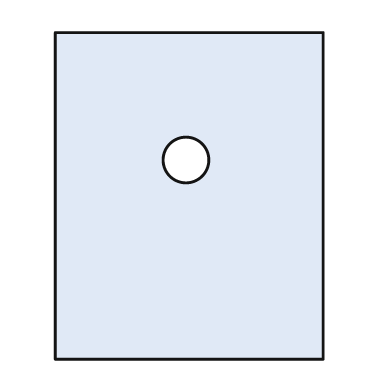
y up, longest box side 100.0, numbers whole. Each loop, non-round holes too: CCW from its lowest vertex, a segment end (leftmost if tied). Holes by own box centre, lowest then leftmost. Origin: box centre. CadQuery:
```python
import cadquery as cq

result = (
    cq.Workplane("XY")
    .moveTo(-41.0, -50.0)
    .lineTo(41.0, -50.0)
    .lineTo(41.0, 50.0)
    .lineTo(-41.0, 50.0)
    .close()
    .moveTo(-1.0, 11.0)
    .circle(7.0)
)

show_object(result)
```